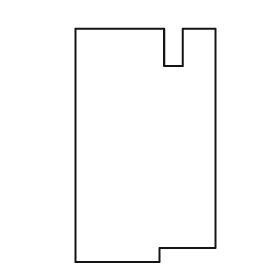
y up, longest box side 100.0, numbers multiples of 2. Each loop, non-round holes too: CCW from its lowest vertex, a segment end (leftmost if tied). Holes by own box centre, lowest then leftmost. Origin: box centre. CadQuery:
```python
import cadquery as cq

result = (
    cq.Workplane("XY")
    .moveTo(-30.0, -50.0)
    .lineTo(6.0, -50.0)
    .lineTo(6.0, -44.0)
    .lineTo(30.0, -44.0)
    .lineTo(30.0, 50.0)
    .lineTo(16.0, 50.0)
    .lineTo(16.0, 34.0)
    .lineTo(8.0, 34.0)
    .lineTo(8.0, 50.0)
    .lineTo(-30.0, 50.0)
    .close()
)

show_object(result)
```